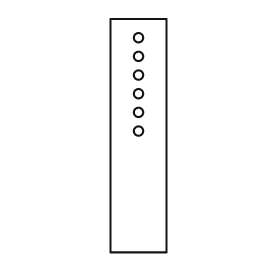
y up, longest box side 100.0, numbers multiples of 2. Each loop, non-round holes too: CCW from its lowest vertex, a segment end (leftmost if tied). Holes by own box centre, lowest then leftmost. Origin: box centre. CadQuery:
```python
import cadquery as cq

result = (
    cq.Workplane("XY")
    .moveTo(-12.0, -50.0)
    .lineTo(12.0, -50.0)
    .lineTo(12.0, 50.0)
    .lineTo(-12.0, 50.0)
    .close()
    .moveTo(0.0, 2.0)
    .circle(2.0)
    .moveTo(0.0, 10.0)
    .circle(2.0)
    .moveTo(0.0, 18.0)
    .circle(2.0)
    .moveTo(0.0, 26.0)
    .circle(2.0)
    .moveTo(0.0, 34.0)
    .circle(2.0)
    .moveTo(0.0, 42.0)
    .circle(2.0)
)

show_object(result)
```